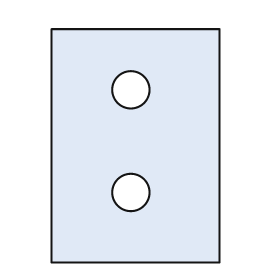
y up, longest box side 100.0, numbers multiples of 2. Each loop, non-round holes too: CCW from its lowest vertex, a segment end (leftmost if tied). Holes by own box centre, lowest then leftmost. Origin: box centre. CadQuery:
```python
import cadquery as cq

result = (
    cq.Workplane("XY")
    .moveTo(-36.0, -50.0)
    .lineTo(36.0, -50.0)
    .lineTo(36.0, 50.0)
    .lineTo(-36.0, 50.0)
    .close()
    .moveTo(-2.0, -20.0)
    .circle(8.0)
    .moveTo(-2.0, 24.0)
    .circle(8.0)
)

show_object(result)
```